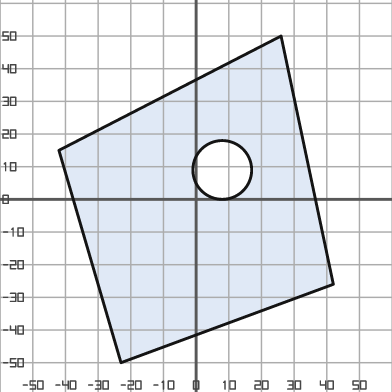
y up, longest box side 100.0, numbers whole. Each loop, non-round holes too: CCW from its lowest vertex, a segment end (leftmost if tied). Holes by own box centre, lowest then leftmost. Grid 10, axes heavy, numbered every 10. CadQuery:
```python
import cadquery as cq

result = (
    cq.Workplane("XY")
    .moveTo(-23.0, -50.0)
    .lineTo(42.0, -26.0)
    .lineTo(26.0, 50.0)
    .lineTo(-42.0, 15.0)
    .close()
    .moveTo(8.0, 9.0)
    .circle(9.0)
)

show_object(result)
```